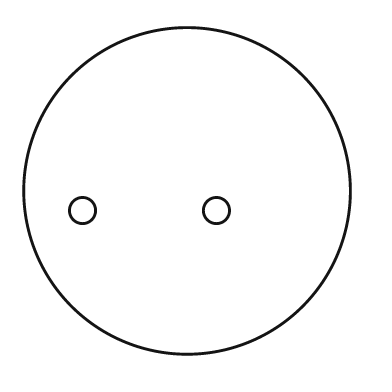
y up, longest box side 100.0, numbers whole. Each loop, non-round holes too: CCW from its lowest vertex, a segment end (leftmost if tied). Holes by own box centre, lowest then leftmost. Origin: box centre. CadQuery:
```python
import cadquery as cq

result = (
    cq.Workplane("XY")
    .moveTo(0.0, 0.0)
    .circle(50.0)
    .moveTo(-32.0, -6.0)
    .circle(4.0)
    .moveTo(9.0, -6.0)
    .circle(4.0)
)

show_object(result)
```